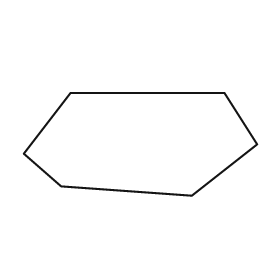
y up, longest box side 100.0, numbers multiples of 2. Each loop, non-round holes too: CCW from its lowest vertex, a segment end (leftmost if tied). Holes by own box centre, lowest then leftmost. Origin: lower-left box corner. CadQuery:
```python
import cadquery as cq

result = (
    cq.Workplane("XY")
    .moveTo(72.0, 0.0)
    .lineTo(100.0, 22.0)
    .lineTo(86.0, 44.0)
    .lineTo(20.0, 44.0)
    .lineTo(0.0, 18.0)
    .lineTo(16.0, 4.0)
    .close()
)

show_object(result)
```